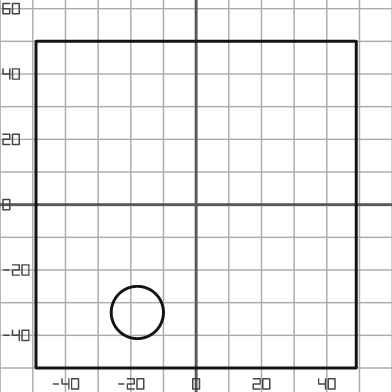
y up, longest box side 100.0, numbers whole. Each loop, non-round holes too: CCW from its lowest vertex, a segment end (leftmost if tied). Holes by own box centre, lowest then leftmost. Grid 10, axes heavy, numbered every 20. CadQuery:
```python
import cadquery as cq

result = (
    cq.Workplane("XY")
    .moveTo(-49.0, -50.0)
    .lineTo(49.0, -50.0)
    .lineTo(49.0, 50.0)
    .lineTo(-49.0, 50.0)
    .close()
    .moveTo(-18.0, -33.0)
    .circle(8.0)
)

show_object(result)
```